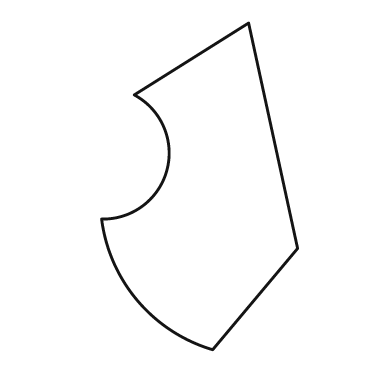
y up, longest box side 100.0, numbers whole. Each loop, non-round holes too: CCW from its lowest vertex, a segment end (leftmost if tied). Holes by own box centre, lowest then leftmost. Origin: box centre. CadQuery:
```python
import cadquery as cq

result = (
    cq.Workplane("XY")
    .moveTo(4.0, -50.0)
    .lineTo(30.0, -19.0)
    .lineTo(15.0, 50.0)
    .lineTo(-20.0, 28.0)
    .threePointArc((-10.0, 5.0), (-30.0, -10.0))
    .threePointArc((-19.0, -35.0), (4.0, -50.0))
    .close()
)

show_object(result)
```